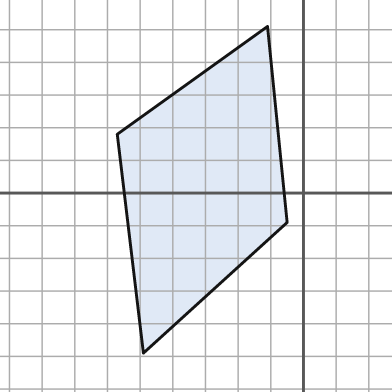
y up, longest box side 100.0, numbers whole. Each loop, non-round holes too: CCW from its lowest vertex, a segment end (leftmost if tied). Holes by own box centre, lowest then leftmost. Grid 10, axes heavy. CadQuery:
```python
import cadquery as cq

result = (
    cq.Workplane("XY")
    .moveTo(-49.0, -49.0)
    .lineTo(-5.0, -9.0)
    .lineTo(-11.0, 51.0)
    .lineTo(-57.0, 18.0)
    .close()
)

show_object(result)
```